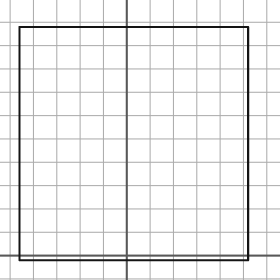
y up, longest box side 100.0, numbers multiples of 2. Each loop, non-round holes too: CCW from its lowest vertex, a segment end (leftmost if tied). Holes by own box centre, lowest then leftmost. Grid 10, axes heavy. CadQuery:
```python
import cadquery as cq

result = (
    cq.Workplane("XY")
    .moveTo(-46.0, -2.0)
    .lineTo(52.0, -2.0)
    .lineTo(52.0, 98.0)
    .lineTo(-46.0, 98.0)
    .close()
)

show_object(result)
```